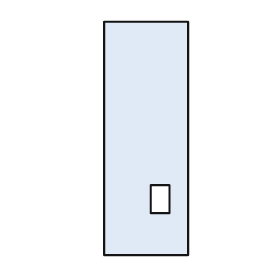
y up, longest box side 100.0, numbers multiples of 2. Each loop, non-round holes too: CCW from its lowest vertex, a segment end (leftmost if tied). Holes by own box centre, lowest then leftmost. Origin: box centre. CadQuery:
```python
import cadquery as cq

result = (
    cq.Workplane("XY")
    .moveTo(-18.0, -50.0)
    .lineTo(18.0, -50.0)
    .lineTo(18.0, 50.0)
    .lineTo(-18.0, 50.0)
    .close()
    .moveTo(2.0, -32.0)
    .lineTo(10.0, -32.0)
    .lineTo(10.0, -20.0)
    .lineTo(2.0, -20.0)
    .close()
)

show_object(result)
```